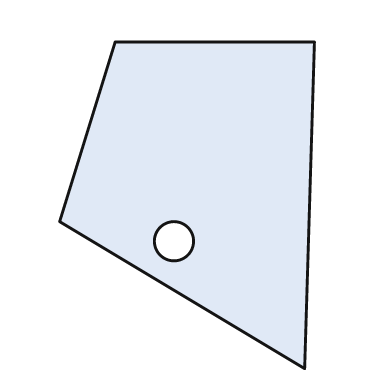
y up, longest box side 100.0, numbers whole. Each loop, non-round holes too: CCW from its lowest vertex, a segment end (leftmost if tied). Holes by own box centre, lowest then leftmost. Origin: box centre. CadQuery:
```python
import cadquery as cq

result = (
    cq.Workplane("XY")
    .moveTo(36.0, -50.0)
    .lineTo(39.0, 50.0)
    .lineTo(-22.0, 50.0)
    .lineTo(-39.0, -5.0)
    .close()
    .moveTo(-4.0, -11.0)
    .circle(6.0)
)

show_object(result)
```